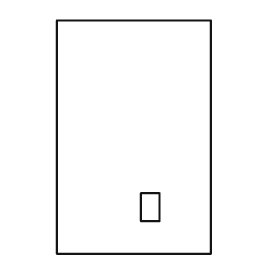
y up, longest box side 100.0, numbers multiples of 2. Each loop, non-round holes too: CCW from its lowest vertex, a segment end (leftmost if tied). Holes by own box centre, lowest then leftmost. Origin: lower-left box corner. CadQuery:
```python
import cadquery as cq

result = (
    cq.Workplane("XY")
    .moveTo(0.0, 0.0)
    .lineTo(66.0, 0.0)
    .lineTo(66.0, 100.0)
    .lineTo(0.0, 100.0)
    .close()
    .moveTo(36.0, 14.0)
    .lineTo(44.0, 14.0)
    .lineTo(44.0, 26.0)
    .lineTo(36.0, 26.0)
    .close()
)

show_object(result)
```